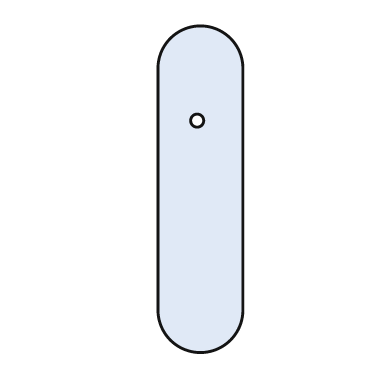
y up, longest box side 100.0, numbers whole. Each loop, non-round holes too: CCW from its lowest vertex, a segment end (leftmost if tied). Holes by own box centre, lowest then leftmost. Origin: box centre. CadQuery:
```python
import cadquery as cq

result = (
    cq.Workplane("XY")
    .moveTo(-13.0, -37.0)
    .threePointArc((0.0, -50.0), (13.0, -37.0))
    .lineTo(13.0, 37.0)
    .threePointArc((0.0, 50.0), (-13.0, 37.0))
    .close()
    .moveTo(-1.0, 21.0)
    .circle(2.0)
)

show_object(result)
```